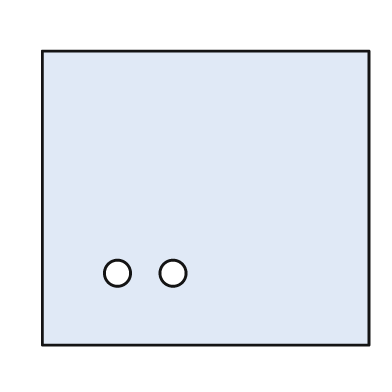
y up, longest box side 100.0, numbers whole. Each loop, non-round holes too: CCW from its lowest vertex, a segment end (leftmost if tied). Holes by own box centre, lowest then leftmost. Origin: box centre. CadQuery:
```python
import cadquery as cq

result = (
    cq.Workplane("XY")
    .moveTo(-50.0, -45.0)
    .lineTo(50.0, -45.0)
    .lineTo(50.0, 45.0)
    .lineTo(-50.0, 45.0)
    .close()
    .moveTo(-27.0, -23.0)
    .circle(4.0)
    .moveTo(-10.0, -23.0)
    .circle(4.0)
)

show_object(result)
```